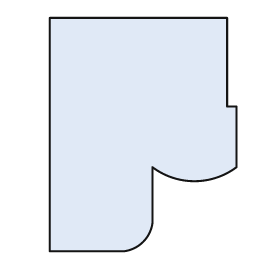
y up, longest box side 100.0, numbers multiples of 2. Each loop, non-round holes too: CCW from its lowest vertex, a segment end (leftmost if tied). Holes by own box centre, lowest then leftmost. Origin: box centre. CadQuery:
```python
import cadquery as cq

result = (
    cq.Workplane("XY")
    .moveTo(-40.0, -50.0)
    .lineTo(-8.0, -50.0)
    .threePointArc((0.0, -46.0), (4.0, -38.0))
    .lineTo(4.0, -14.0)
    .threePointArc((22.0, -20.0), (40.0, -14.0))
    .lineTo(40.0, 12.0)
    .lineTo(36.0, 12.0)
    .lineTo(36.0, 50.0)
    .lineTo(-40.0, 50.0)
    .close()
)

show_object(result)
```